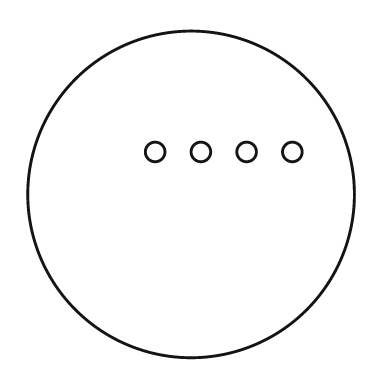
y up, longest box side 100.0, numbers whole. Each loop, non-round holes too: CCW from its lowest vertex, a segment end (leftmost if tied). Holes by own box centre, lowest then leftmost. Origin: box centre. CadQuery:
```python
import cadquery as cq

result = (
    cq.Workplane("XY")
    .moveTo(0.0, 0.0)
    .circle(50.0)
    .moveTo(-11.0, 13.0)
    .circle(3.0)
    .moveTo(3.0, 13.0)
    .circle(3.0)
    .moveTo(17.0, 13.0)
    .circle(3.0)
    .moveTo(31.0, 13.0)
    .circle(3.0)
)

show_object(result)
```